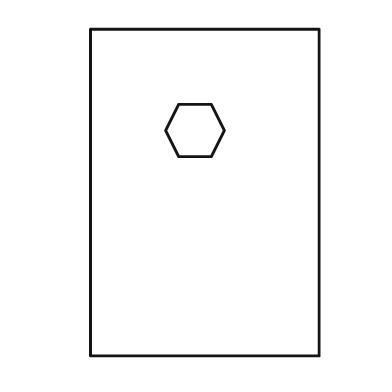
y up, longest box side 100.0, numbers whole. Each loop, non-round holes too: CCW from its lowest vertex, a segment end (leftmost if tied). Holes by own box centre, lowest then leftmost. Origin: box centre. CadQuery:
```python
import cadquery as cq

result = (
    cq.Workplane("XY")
    .moveTo(-35.0, -50.0)
    .lineTo(35.0, -50.0)
    .lineTo(35.0, 50.0)
    .lineTo(-35.0, 50.0)
    .close()
    .moveTo(-8.0, 11.0)
    .lineTo(2.0, 11.0)
    .lineTo(6.0, 19.0)
    .lineTo(2.0, 27.0)
    .lineTo(-8.0, 27.0)
    .lineTo(-12.0, 19.0)
    .close()
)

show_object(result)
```